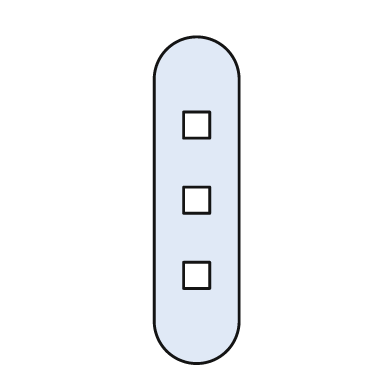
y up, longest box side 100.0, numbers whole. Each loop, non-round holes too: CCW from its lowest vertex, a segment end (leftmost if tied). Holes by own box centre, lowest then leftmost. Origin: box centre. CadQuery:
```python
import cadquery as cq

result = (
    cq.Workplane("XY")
    .moveTo(-13.0, -37.0)
    .threePointArc((0.0, -50.0), (13.0, -37.0))
    .lineTo(13.0, 37.0)
    .threePointArc((0.0, 50.0), (-13.0, 37.0))
    .close()
    .moveTo(-4.0, -27.0)
    .lineTo(4.0, -27.0)
    .lineTo(4.0, -19.0)
    .lineTo(-4.0, -19.0)
    .close()
    .moveTo(-4.0, -4.0)
    .lineTo(4.0, -4.0)
    .lineTo(4.0, 4.0)
    .lineTo(-4.0, 4.0)
    .close()
    .moveTo(-4.0, 19.0)
    .lineTo(4.0, 19.0)
    .lineTo(4.0, 27.0)
    .lineTo(-4.0, 27.0)
    .close()
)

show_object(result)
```